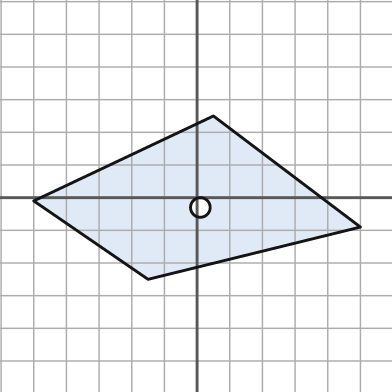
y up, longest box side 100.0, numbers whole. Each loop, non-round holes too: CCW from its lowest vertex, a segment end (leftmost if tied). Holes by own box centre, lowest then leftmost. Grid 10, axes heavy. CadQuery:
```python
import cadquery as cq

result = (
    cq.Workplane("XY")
    .moveTo(-15.0, -25.0)
    .lineTo(50.0, -9.0)
    .lineTo(5.0, 25.0)
    .lineTo(-50.0, -1.0)
    .close()
    .moveTo(1.0, -3.0)
    .circle(3.0)
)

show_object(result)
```